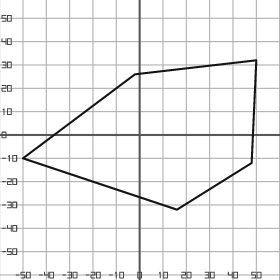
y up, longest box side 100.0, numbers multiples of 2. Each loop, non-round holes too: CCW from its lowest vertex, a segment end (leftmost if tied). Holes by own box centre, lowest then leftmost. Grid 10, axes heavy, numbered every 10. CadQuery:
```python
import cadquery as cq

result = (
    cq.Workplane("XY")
    .moveTo(16.0, -32.0)
    .lineTo(48.0, -12.0)
    .lineTo(50.0, 32.0)
    .lineTo(-2.0, 26.0)
    .lineTo(-50.0, -10.0)
    .close()
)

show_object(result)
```